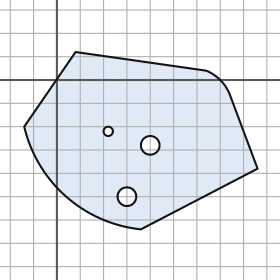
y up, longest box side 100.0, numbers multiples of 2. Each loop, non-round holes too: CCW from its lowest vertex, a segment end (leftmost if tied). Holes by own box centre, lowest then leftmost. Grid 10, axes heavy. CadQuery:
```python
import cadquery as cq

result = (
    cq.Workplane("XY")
    .moveTo(36.0, -64.0)
    .lineTo(86.0, -38.0)
    .lineTo(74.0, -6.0)
    .threePointArc((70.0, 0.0), (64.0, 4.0))
    .lineTo(8.0, 12.0)
    .lineTo(-14.0, -20.0)
    .threePointArc((4.0, -50.0), (36.0, -64.0))
    .close()
    .moveTo(30.0, -50.0)
    .circle(4.0)
    .moveTo(40.0, -28.0)
    .circle(4.0)
    .moveTo(22.0, -22.0)
    .circle(2.0)
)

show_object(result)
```